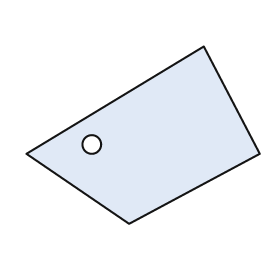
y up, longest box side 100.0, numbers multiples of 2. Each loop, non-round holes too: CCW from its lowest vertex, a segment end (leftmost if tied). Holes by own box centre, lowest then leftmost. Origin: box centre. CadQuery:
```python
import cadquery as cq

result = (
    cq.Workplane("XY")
    .moveTo(-6.0, -38.0)
    .lineTo(50.0, -8.0)
    .lineTo(26.0, 38.0)
    .lineTo(-50.0, -8.0)
    .close()
    .moveTo(-22.0, -4.0)
    .circle(4.0)
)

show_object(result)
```